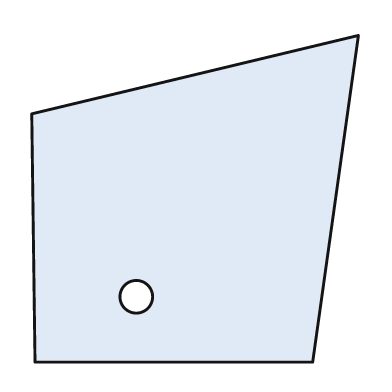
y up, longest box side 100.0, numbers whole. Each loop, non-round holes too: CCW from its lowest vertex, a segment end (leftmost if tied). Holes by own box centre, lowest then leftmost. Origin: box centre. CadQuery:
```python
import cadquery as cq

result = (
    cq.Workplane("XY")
    .moveTo(-49.0, -50.0)
    .lineTo(36.0, -50.0)
    .lineTo(50.0, 50.0)
    .lineTo(-50.0, 26.0)
    .close()
    .moveTo(-18.0, -30.0)
    .circle(5.0)
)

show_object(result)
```